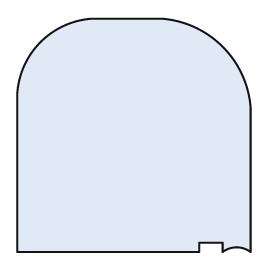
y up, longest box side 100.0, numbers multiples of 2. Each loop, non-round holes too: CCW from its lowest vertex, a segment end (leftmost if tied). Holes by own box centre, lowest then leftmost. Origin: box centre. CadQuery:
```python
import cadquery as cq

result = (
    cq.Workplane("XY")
    .moveTo(-50.0, -50.0)
    .lineTo(28.0, -50.0)
    .lineTo(28.0, -46.0)
    .lineTo(38.0, -46.0)
    .lineTo(38.0, -50.0)
    .threePointArc((44.0, -48.0), (50.0, -50.0))
    .lineTo(50.0, 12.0)
    .threePointArc((38.0, 38.0), (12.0, 50.0))
    .lineTo(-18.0, 50.0)
    .threePointArc((-40.0, 40.0), (-50.0, 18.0))
    .close()
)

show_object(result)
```